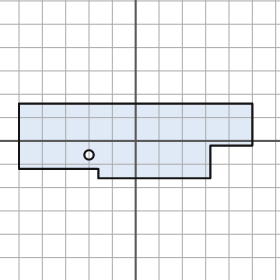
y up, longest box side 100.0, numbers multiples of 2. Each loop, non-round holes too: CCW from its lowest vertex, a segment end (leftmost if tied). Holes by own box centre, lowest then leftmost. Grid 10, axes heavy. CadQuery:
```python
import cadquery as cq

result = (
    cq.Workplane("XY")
    .moveTo(-16.0, -16.0)
    .lineTo(32.0, -16.0)
    .lineTo(32.0, -2.0)
    .lineTo(50.0, -2.0)
    .lineTo(50.0, 16.0)
    .lineTo(-50.0, 16.0)
    .lineTo(-50.0, -12.0)
    .lineTo(-16.0, -12.0)
    .close()
    .moveTo(-20.0, -6.0)
    .circle(2.0)
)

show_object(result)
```